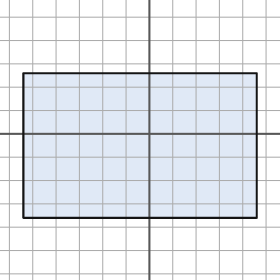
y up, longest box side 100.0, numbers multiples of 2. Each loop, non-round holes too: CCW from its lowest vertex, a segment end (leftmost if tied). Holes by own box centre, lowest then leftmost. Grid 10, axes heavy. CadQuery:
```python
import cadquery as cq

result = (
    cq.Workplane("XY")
    .moveTo(-54.0, -36.0)
    .lineTo(46.0, -36.0)
    .lineTo(46.0, 26.0)
    .lineTo(-54.0, 26.0)
    .close()
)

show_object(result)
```